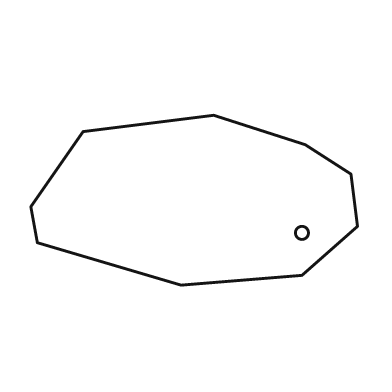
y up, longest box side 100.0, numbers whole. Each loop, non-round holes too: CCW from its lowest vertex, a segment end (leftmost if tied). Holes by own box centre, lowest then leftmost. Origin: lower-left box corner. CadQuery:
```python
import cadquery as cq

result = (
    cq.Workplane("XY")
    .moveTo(46.0, 0.0)
    .lineTo(83.0, 3.0)
    .lineTo(100.0, 18.0)
    .lineTo(98.0, 34.0)
    .lineTo(84.0, 43.0)
    .lineTo(56.0, 52.0)
    .lineTo(16.0, 47.0)
    .lineTo(0.0, 24.0)
    .lineTo(2.0, 13.0)
    .close()
    .moveTo(83.0, 16.0)
    .circle(2.0)
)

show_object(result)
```